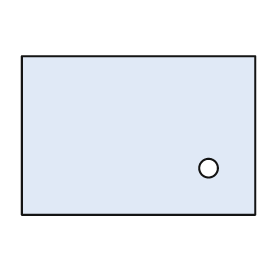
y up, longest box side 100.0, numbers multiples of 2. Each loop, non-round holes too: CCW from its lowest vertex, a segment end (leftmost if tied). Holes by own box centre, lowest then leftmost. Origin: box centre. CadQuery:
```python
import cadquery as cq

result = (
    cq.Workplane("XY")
    .moveTo(-50.0, -34.0)
    .lineTo(50.0, -34.0)
    .lineTo(50.0, 34.0)
    .lineTo(-50.0, 34.0)
    .close()
    .moveTo(30.0, -14.0)
    .circle(4.0)
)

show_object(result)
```